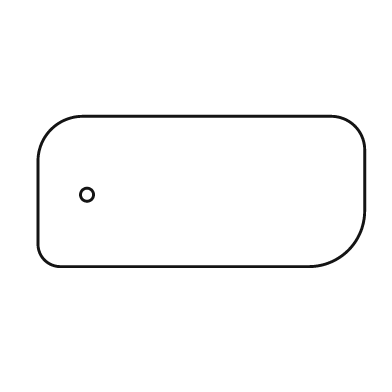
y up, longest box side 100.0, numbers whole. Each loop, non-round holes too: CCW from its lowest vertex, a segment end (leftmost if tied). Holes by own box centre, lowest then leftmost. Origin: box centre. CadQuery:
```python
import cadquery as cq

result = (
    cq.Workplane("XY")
    .moveTo(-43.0, -23.0)
    .lineTo(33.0, -23.0)
    .threePointArc((45.0, -18.0), (50.0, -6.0))
    .lineTo(50.0, 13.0)
    .threePointArc((47.0, 20.0), (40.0, 23.0))
    .lineTo(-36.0, 23.0)
    .threePointArc((-46.0, 19.0), (-50.0, 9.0))
    .lineTo(-50.0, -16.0)
    .threePointArc((-48.0, -21.0), (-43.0, -23.0))
    .close()
    .moveTo(-35.0, -1.0)
    .circle(2.0)
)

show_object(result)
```